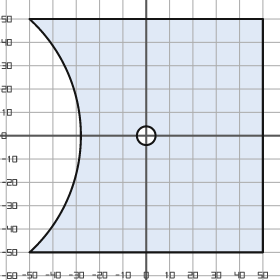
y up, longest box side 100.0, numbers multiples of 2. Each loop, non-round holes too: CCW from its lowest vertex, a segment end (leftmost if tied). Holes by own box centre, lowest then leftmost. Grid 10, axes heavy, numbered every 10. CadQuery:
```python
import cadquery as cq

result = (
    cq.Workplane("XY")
    .moveTo(-50.0, -50.0)
    .lineTo(50.0, -50.0)
    .lineTo(50.0, 50.0)
    .lineTo(-50.0, 50.0)
    .threePointArc((-28.0, 0.0), (-50.0, -50.0))
    .close()
    .moveTo(0.0, 0.0)
    .circle(4.0)
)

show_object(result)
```